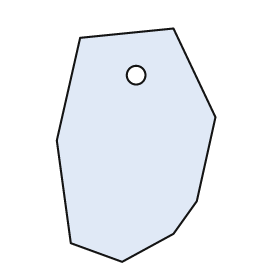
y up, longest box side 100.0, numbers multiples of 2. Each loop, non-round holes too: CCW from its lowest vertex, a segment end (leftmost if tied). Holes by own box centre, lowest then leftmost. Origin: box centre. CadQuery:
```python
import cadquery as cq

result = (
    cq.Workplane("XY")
    .moveTo(-6.0, -50.0)
    .lineTo(16.0, -38.0)
    .lineTo(26.0, -24.0)
    .lineTo(34.0, 12.0)
    .lineTo(16.0, 50.0)
    .lineTo(-24.0, 46.0)
    .lineTo(-34.0, 2.0)
    .lineTo(-28.0, -42.0)
    .close()
    .moveTo(0.0, 30.0)
    .circle(4.0)
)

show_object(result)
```